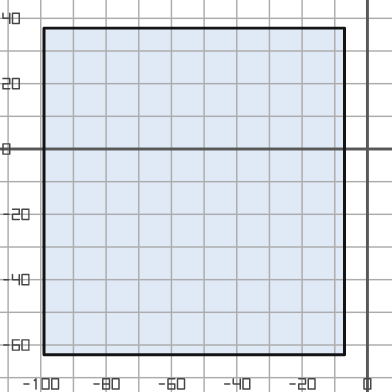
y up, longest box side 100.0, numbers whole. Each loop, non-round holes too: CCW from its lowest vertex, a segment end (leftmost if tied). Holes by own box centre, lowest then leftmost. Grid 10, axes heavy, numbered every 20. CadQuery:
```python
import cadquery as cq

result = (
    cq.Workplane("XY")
    .moveTo(-99.0, -63.0)
    .lineTo(-7.0, -63.0)
    .lineTo(-7.0, 37.0)
    .lineTo(-99.0, 37.0)
    .close()
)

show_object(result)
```